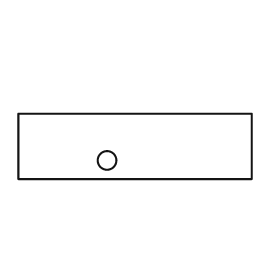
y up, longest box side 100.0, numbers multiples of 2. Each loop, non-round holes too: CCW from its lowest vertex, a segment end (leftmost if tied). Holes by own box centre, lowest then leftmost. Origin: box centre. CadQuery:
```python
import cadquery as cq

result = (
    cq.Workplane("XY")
    .moveTo(-50.0, -14.0)
    .lineTo(50.0, -14.0)
    .lineTo(50.0, 14.0)
    .lineTo(-50.0, 14.0)
    .close()
    .moveTo(-12.0, -6.0)
    .circle(4.0)
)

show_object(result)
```